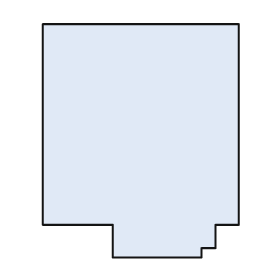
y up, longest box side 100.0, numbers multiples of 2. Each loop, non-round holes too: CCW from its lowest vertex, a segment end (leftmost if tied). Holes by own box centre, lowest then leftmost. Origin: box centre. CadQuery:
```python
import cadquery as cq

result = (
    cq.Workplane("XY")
    .moveTo(-12.0, -50.0)
    .lineTo(26.0, -50.0)
    .lineTo(26.0, -46.0)
    .lineTo(32.0, -46.0)
    .lineTo(32.0, -36.0)
    .lineTo(42.0, -36.0)
    .lineTo(42.0, 50.0)
    .lineTo(-42.0, 50.0)
    .lineTo(-42.0, -36.0)
    .lineTo(-12.0, -36.0)
    .close()
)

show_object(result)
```